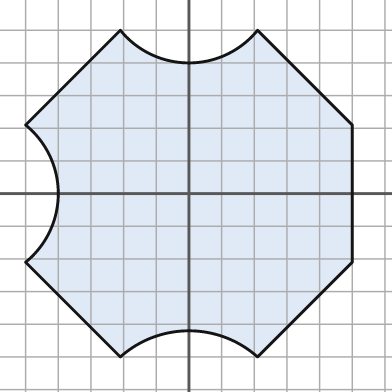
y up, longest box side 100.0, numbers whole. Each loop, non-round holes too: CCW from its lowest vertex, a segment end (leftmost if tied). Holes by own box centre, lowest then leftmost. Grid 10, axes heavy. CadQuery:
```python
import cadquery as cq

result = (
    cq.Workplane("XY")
    .moveTo(-21.0, -50.0)
    .threePointArc((0.0, -42.0), (21.0, -50.0))
    .lineTo(50.0, -21.0)
    .lineTo(50.0, 21.0)
    .lineTo(21.0, 50.0)
    .threePointArc((0.0, 40.0), (-21.0, 50.0))
    .lineTo(-50.0, 21.0)
    .threePointArc((-40.0, 0.0), (-50.0, -21.0))
    .close()
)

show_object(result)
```